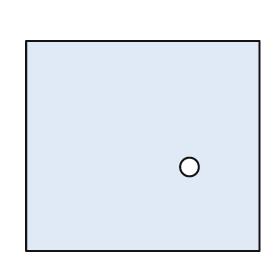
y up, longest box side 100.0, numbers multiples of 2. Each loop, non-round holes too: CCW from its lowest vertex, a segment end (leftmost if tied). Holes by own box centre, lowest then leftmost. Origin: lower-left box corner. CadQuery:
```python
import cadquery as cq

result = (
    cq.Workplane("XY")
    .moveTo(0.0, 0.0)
    .lineTo(100.0, 0.0)
    .lineTo(100.0, 90.0)
    .lineTo(0.0, 90.0)
    .close()
    .moveTo(70.0, 36.0)
    .circle(4.0)
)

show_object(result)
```